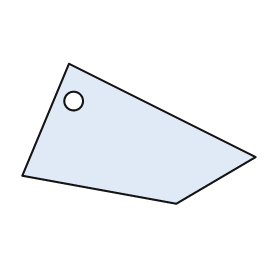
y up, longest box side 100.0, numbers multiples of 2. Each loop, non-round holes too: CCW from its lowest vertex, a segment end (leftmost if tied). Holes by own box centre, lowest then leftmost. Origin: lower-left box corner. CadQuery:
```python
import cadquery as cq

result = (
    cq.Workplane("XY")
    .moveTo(66.0, 0.0)
    .lineTo(100.0, 20.0)
    .lineTo(20.0, 60.0)
    .lineTo(0.0, 12.0)
    .close()
    .moveTo(22.0, 44.0)
    .circle(4.0)
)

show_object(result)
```